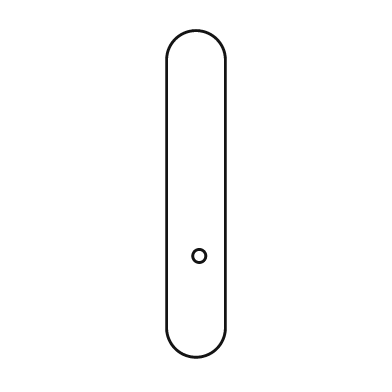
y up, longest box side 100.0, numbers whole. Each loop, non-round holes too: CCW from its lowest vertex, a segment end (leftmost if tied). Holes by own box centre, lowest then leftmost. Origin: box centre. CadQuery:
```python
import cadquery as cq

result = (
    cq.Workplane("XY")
    .moveTo(-9.0, -41.0)
    .threePointArc((0.0, -50.0), (9.0, -41.0))
    .lineTo(9.0, 41.0)
    .threePointArc((0.0, 50.0), (-9.0, 41.0))
    .close()
    .moveTo(1.0, -19.0)
    .circle(2.0)
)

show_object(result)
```